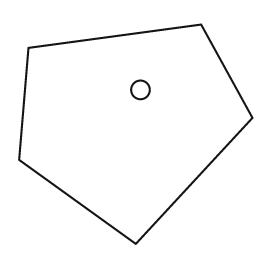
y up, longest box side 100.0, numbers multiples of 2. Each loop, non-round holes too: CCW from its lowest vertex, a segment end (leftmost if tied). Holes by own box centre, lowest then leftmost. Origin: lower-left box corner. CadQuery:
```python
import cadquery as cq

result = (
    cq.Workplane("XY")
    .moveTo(50.0, 0.0)
    .lineTo(100.0, 54.0)
    .lineTo(78.0, 94.0)
    .lineTo(4.0, 84.0)
    .lineTo(0.0, 36.0)
    .close()
    .moveTo(52.0, 66.0)
    .circle(4.0)
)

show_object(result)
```